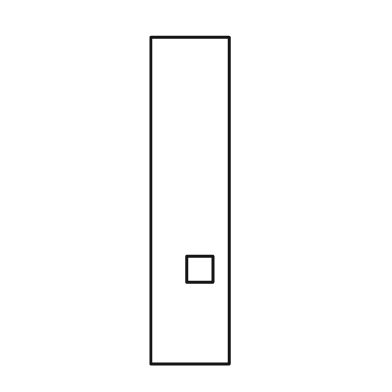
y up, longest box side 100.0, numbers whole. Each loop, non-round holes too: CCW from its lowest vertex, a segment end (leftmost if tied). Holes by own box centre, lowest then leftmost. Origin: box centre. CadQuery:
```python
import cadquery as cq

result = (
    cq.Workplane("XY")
    .moveTo(-12.0, -50.0)
    .lineTo(12.0, -50.0)
    .lineTo(12.0, 50.0)
    .lineTo(-12.0, 50.0)
    .close()
    .moveTo(-1.0, -25.0)
    .lineTo(7.0, -25.0)
    .lineTo(7.0, -17.0)
    .lineTo(-1.0, -17.0)
    .close()
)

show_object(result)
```